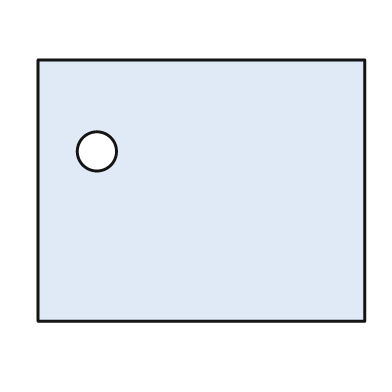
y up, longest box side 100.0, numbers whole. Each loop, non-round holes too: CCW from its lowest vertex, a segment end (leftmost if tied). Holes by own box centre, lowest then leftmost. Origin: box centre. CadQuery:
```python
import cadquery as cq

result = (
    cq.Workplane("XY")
    .moveTo(-50.0, -40.0)
    .lineTo(50.0, -40.0)
    .lineTo(50.0, 40.0)
    .lineTo(-50.0, 40.0)
    .close()
    .moveTo(-32.0, 12.0)
    .circle(6.0)
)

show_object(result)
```